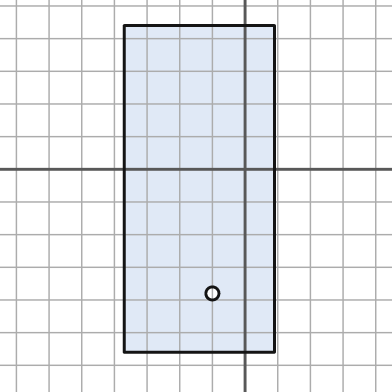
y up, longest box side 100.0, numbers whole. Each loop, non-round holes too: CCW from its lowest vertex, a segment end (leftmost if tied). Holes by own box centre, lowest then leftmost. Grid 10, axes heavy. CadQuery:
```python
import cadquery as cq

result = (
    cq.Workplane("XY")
    .moveTo(-37.0, -56.0)
    .lineTo(9.0, -56.0)
    .lineTo(9.0, 44.0)
    .lineTo(-37.0, 44.0)
    .close()
    .moveTo(-10.0, -38.0)
    .circle(2.0)
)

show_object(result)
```